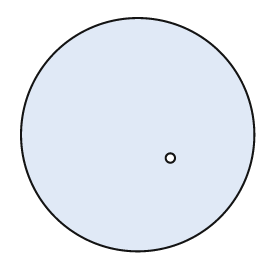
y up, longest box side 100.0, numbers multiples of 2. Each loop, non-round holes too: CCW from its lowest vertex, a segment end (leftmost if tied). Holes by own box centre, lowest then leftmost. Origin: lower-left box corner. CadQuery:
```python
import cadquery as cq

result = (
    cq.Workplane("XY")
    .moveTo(50.0, 50.0)
    .circle(50.0)
    .moveTo(64.0, 40.0)
    .circle(2.0)
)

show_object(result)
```